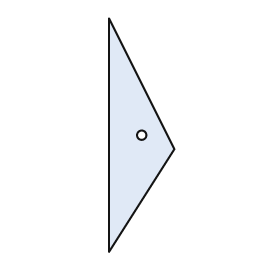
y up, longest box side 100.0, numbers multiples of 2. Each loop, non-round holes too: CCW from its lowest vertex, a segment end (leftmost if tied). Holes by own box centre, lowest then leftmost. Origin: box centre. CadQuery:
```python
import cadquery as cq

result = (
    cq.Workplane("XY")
    .moveTo(-14.0, -50.0)
    .lineTo(14.0, -6.0)
    .lineTo(-14.0, 50.0)
    .close()
    .moveTo(0.0, 0.0)
    .circle(2.0)
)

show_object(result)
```